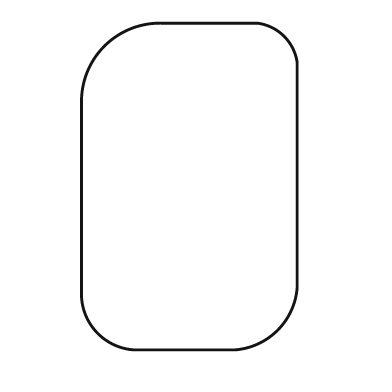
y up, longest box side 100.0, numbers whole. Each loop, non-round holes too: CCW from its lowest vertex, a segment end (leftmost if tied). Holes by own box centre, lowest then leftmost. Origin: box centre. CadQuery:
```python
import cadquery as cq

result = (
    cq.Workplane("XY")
    .moveTo(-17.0, -50.0)
    .lineTo(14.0, -50.0)
    .threePointArc((27.0, -44.0), (33.0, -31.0))
    .lineTo(33.0, 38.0)
    .threePointArc((29.0, 46.0), (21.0, 50.0))
    .lineTo(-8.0, 50.0)
    .threePointArc((-26.0, 43.0), (-33.0, 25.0))
    .lineTo(-33.0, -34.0)
    .threePointArc((-28.0, -45.0), (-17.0, -50.0))
    .close()
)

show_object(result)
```